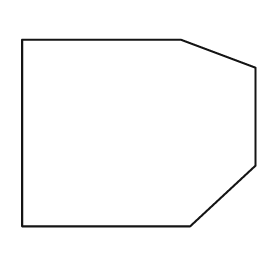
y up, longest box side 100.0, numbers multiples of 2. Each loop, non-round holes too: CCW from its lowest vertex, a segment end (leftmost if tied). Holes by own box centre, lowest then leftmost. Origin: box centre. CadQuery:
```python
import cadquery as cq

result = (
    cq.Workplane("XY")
    .moveTo(-50.0, -40.0)
    .lineTo(22.0, -40.0)
    .lineTo(50.0, -14.0)
    .lineTo(50.0, 28.0)
    .lineTo(18.0, 40.0)
    .lineTo(-50.0, 40.0)
    .close()
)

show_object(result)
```